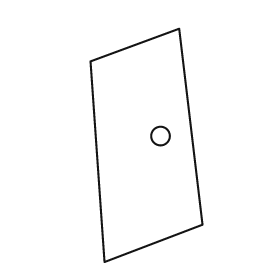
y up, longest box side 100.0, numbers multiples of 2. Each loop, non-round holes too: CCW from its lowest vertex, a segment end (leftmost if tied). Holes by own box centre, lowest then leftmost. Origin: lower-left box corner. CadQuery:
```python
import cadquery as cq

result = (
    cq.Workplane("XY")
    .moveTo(6.0, 0.0)
    .lineTo(48.0, 16.0)
    .lineTo(38.0, 100.0)
    .lineTo(0.0, 86.0)
    .close()
    .moveTo(30.0, 54.0)
    .circle(4.0)
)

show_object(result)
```